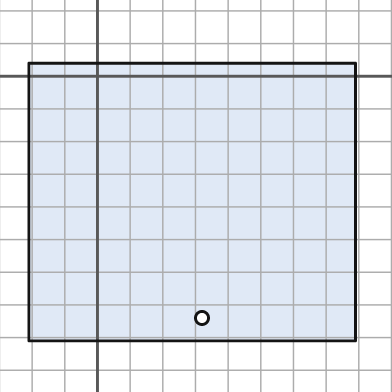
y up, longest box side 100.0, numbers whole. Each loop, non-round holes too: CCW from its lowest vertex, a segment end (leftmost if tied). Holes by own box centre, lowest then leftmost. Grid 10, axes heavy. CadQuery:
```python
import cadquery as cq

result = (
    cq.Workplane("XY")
    .moveTo(-21.0, -81.0)
    .lineTo(79.0, -81.0)
    .lineTo(79.0, 4.0)
    .lineTo(-21.0, 4.0)
    .close()
    .moveTo(32.0, -74.0)
    .circle(2.0)
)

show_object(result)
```